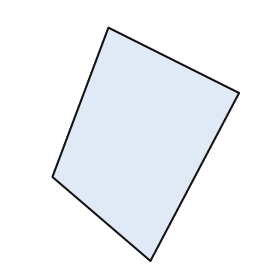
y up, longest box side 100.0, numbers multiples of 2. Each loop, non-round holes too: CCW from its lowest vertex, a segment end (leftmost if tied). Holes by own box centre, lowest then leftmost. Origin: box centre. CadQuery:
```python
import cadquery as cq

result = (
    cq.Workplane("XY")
    .moveTo(2.0, -50.0)
    .lineTo(40.0, 22.0)
    .lineTo(-16.0, 50.0)
    .lineTo(-40.0, -14.0)
    .close()
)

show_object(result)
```